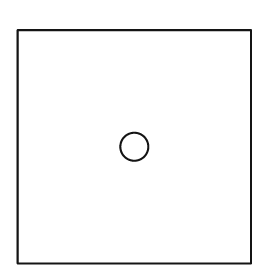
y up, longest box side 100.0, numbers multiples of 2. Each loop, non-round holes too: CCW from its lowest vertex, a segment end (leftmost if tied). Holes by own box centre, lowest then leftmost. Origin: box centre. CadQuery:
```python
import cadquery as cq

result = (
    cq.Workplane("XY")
    .moveTo(-50.0, -50.0)
    .lineTo(50.0, -50.0)
    .lineTo(50.0, 50.0)
    .lineTo(-50.0, 50.0)
    .close()
    .moveTo(0.0, 0.0)
    .circle(6.0)
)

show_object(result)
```